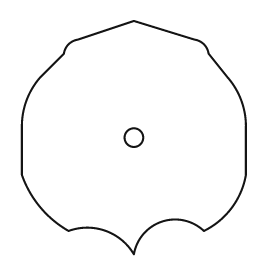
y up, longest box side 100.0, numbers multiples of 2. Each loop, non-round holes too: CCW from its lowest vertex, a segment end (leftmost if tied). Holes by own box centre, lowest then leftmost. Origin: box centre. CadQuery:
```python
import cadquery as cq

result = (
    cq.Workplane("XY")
    .moveTo(0.0, -50.0)
    .threePointArc((12.0, -36.0), (30.0, -40.0))
    .threePointArc((42.0, -30.0), (48.0, -16.0))
    .lineTo(48.0, 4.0)
    .threePointArc((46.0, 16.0), (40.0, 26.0))
    .lineTo(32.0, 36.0)
    .threePointArc((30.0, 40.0), (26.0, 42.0))
    .lineTo(0.0, 50.0)
    .lineTo(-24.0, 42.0)
    .threePointArc((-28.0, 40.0), (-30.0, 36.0))
    .lineTo(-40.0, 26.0)
    .threePointArc((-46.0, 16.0), (-48.0, 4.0))
    .lineTo(-48.0, -16.0)
    .threePointArc((-40.0, -30.0), (-28.0, -40.0))
    .threePointArc((-12.0, -40.0), (0.0, -50.0))
    .close()
    .moveTo(0.0, 0.0)
    .circle(4.0)
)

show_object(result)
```